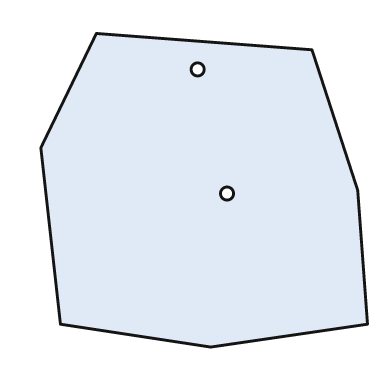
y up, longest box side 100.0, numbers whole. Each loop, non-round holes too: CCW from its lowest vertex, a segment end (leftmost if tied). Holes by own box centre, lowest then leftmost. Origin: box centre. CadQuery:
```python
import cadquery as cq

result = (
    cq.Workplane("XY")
    .moveTo(2.0, -48.0)
    .lineTo(50.0, -41.0)
    .lineTo(47.0, 0.0)
    .lineTo(33.0, 43.0)
    .lineTo(-33.0, 48.0)
    .lineTo(-50.0, 13.0)
    .lineTo(-44.0, -41.0)
    .close()
    .moveTo(7.0, -1.0)
    .circle(2.0)
    .moveTo(-2.0, 37.0)
    .circle(2.0)
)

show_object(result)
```